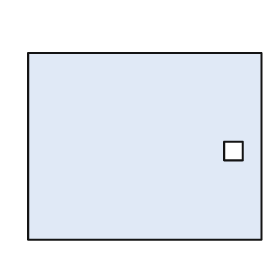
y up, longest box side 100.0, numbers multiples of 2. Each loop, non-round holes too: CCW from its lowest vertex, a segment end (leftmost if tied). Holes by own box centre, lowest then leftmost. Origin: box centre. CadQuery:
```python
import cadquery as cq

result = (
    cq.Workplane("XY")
    .moveTo(-50.0, -40.0)
    .lineTo(50.0, -40.0)
    .lineTo(50.0, 40.0)
    .lineTo(-50.0, 40.0)
    .close()
    .moveTo(34.0, -6.0)
    .lineTo(42.0, -6.0)
    .lineTo(42.0, 2.0)
    .lineTo(34.0, 2.0)
    .close()
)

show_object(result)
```